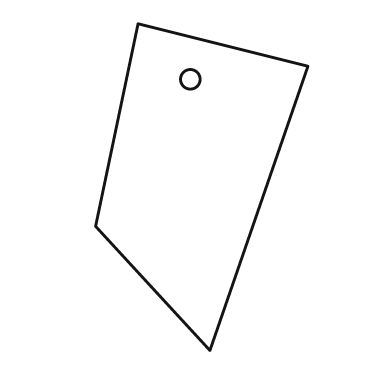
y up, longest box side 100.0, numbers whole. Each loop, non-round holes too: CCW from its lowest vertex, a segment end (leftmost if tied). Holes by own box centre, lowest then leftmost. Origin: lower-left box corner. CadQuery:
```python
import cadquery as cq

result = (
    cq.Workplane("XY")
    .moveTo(35.0, 0.0)
    .lineTo(65.0, 87.0)
    .lineTo(13.0, 100.0)
    .lineTo(0.0, 38.0)
    .close()
    .moveTo(29.0, 83.0)
    .circle(3.0)
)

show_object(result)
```